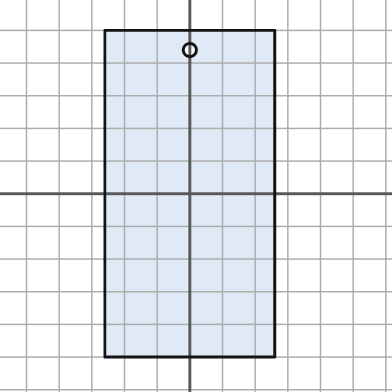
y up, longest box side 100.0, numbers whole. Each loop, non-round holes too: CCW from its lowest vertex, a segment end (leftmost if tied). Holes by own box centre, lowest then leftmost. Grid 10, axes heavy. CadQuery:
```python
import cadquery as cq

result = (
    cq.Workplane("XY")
    .moveTo(-26.0, -50.0)
    .lineTo(26.0, -50.0)
    .lineTo(26.0, 50.0)
    .lineTo(-26.0, 50.0)
    .close()
    .moveTo(0.0, 44.0)
    .circle(2.0)
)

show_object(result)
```